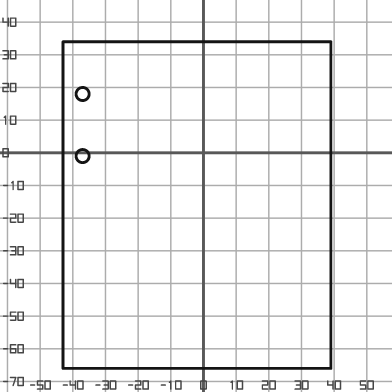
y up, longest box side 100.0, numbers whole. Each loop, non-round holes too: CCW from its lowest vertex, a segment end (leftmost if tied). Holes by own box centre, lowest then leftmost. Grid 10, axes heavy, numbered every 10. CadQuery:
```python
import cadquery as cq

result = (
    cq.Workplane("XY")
    .moveTo(-43.0, -66.0)
    .lineTo(39.0, -66.0)
    .lineTo(39.0, 34.0)
    .lineTo(-43.0, 34.0)
    .close()
    .moveTo(-37.0, -1.0)
    .circle(2.0)
    .moveTo(-37.0, 18.0)
    .circle(2.0)
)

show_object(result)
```